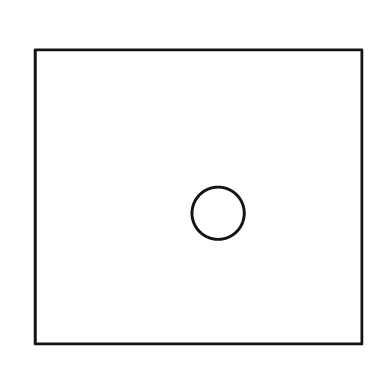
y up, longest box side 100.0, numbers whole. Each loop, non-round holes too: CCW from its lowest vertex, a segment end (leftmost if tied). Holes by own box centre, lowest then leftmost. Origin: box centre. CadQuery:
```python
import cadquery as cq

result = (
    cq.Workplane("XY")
    .moveTo(-50.0, -45.0)
    .lineTo(50.0, -45.0)
    .lineTo(50.0, 45.0)
    .lineTo(-50.0, 45.0)
    .close()
    .moveTo(6.0, -5.0)
    .circle(8.0)
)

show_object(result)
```